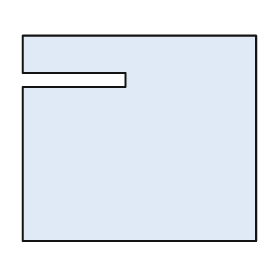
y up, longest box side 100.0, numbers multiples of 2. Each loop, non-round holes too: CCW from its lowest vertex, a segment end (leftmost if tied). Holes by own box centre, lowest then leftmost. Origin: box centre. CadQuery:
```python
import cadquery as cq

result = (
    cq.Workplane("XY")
    .moveTo(-50.0, -44.0)
    .lineTo(50.0, -44.0)
    .lineTo(50.0, 44.0)
    .lineTo(-50.0, 44.0)
    .lineTo(-50.0, 28.0)
    .lineTo(-6.0, 28.0)
    .lineTo(-6.0, 22.0)
    .lineTo(-50.0, 22.0)
    .close()
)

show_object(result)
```